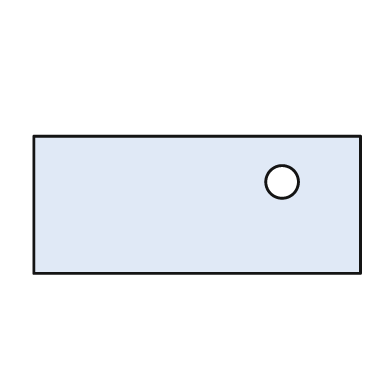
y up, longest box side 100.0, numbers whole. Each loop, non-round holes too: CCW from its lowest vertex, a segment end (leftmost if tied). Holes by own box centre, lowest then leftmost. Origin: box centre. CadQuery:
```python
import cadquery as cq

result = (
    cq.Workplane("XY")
    .moveTo(-50.0, -21.0)
    .lineTo(50.0, -21.0)
    .lineTo(50.0, 21.0)
    .lineTo(-50.0, 21.0)
    .close()
    .moveTo(26.0, 7.0)
    .circle(5.0)
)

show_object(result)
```